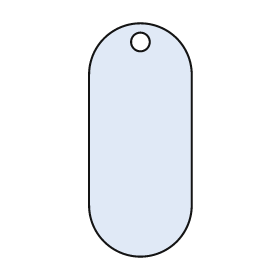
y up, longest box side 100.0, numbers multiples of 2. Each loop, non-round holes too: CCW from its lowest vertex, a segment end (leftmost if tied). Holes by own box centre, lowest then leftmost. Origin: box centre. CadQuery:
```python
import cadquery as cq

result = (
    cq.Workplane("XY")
    .moveTo(-22.0, -28.0)
    .threePointArc((0.0, -50.0), (22.0, -28.0))
    .lineTo(22.0, 28.0)
    .threePointArc((0.0, 50.0), (-22.0, 28.0))
    .close()
    .moveTo(0.0, 42.0)
    .circle(4.0)
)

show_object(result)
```